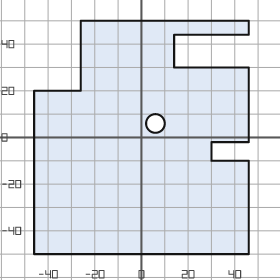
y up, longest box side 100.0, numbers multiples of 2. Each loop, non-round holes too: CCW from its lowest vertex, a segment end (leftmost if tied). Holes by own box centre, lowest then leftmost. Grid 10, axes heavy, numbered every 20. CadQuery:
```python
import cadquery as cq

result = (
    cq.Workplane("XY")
    .moveTo(-46.0, -50.0)
    .lineTo(46.0, -50.0)
    .lineTo(46.0, -10.0)
    .lineTo(30.0, -10.0)
    .lineTo(30.0, -2.0)
    .lineTo(46.0, -2.0)
    .lineTo(46.0, 30.0)
    .lineTo(14.0, 30.0)
    .lineTo(14.0, 44.0)
    .lineTo(46.0, 44.0)
    .lineTo(46.0, 50.0)
    .lineTo(-26.0, 50.0)
    .lineTo(-26.0, 20.0)
    .lineTo(-46.0, 20.0)
    .close()
    .moveTo(6.0, 6.0)
    .circle(4.0)
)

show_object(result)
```